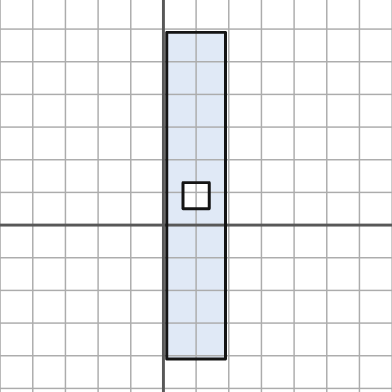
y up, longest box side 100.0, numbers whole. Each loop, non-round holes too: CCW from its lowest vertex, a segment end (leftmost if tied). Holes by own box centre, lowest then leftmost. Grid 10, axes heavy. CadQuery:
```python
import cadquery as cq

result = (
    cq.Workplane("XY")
    .moveTo(1.0, -41.0)
    .lineTo(19.0, -41.0)
    .lineTo(19.0, 59.0)
    .lineTo(1.0, 59.0)
    .close()
    .moveTo(6.0, 5.0)
    .lineTo(14.0, 5.0)
    .lineTo(14.0, 13.0)
    .lineTo(6.0, 13.0)
    .close()
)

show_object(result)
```